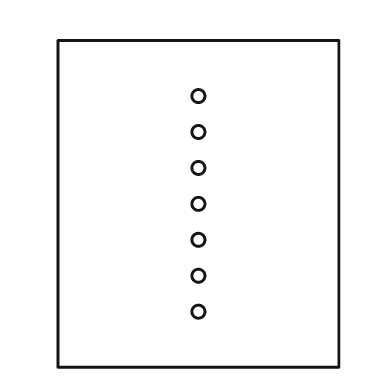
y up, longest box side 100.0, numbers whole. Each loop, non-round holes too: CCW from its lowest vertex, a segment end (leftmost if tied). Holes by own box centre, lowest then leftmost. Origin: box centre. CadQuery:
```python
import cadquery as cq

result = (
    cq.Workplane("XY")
    .moveTo(-43.0, -50.0)
    .lineTo(43.0, -50.0)
    .lineTo(43.0, 50.0)
    .lineTo(-43.0, 50.0)
    .close()
    .moveTo(0.0, -33.0)
    .circle(2.0)
    .moveTo(0.0, -22.0)
    .circle(2.0)
    .moveTo(0.0, -11.0)
    .circle(2.0)
    .moveTo(0.0, 0.0)
    .circle(2.0)
    .moveTo(0.0, 11.0)
    .circle(2.0)
    .moveTo(0.0, 22.0)
    .circle(2.0)
    .moveTo(0.0, 33.0)
    .circle(2.0)
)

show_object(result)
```